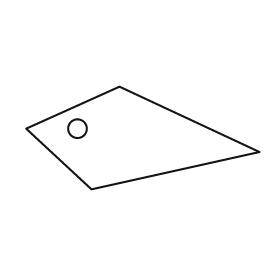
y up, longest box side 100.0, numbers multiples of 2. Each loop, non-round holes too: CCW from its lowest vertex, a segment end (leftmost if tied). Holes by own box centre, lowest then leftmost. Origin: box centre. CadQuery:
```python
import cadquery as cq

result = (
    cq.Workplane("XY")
    .moveTo(-22.0, -22.0)
    .lineTo(50.0, -6.0)
    .lineTo(-10.0, 22.0)
    .lineTo(-50.0, 4.0)
    .close()
    .moveTo(-28.0, 4.0)
    .circle(4.0)
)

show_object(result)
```